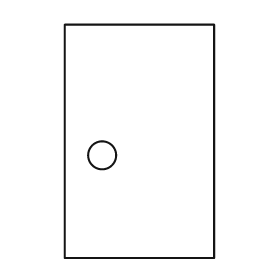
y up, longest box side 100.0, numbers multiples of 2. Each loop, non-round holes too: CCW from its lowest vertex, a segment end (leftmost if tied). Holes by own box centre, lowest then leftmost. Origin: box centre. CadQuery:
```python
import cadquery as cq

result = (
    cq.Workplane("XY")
    .moveTo(-32.0, -50.0)
    .lineTo(32.0, -50.0)
    .lineTo(32.0, 50.0)
    .lineTo(-32.0, 50.0)
    .close()
    .moveTo(-16.0, -6.0)
    .circle(6.0)
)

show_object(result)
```